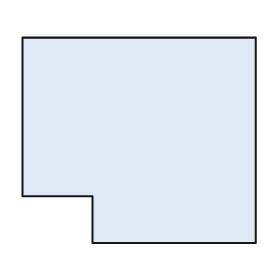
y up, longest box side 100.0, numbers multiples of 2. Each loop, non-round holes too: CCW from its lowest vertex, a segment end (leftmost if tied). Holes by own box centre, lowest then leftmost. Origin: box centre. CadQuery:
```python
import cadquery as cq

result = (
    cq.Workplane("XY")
    .moveTo(-20.0, -44.0)
    .lineTo(50.0, -44.0)
    .lineTo(50.0, 44.0)
    .lineTo(-50.0, 44.0)
    .lineTo(-50.0, -24.0)
    .lineTo(-20.0, -24.0)
    .close()
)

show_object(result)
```